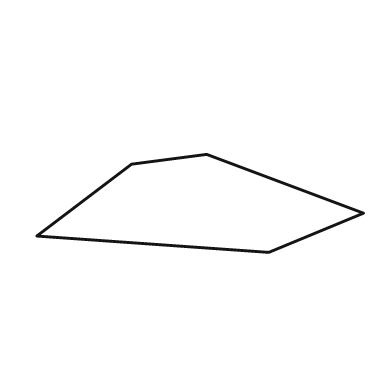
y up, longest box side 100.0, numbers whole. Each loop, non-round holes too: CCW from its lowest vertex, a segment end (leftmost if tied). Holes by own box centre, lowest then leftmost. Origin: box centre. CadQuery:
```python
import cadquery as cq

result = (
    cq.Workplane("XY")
    .moveTo(21.0, -15.0)
    .lineTo(50.0, -3.0)
    .lineTo(2.0, 15.0)
    .lineTo(-21.0, 12.0)
    .lineTo(-50.0, -10.0)
    .close()
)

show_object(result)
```